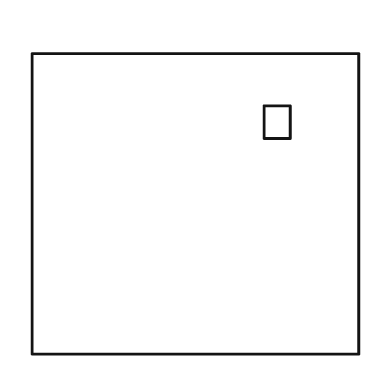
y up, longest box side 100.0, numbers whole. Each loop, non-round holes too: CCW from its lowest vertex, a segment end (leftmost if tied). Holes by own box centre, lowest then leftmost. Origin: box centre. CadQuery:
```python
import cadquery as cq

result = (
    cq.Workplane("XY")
    .moveTo(-50.0, -46.0)
    .lineTo(50.0, -46.0)
    .lineTo(50.0, 46.0)
    .lineTo(-50.0, 46.0)
    .close()
    .moveTo(21.0, 20.0)
    .lineTo(29.0, 20.0)
    .lineTo(29.0, 30.0)
    .lineTo(21.0, 30.0)
    .close()
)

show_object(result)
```